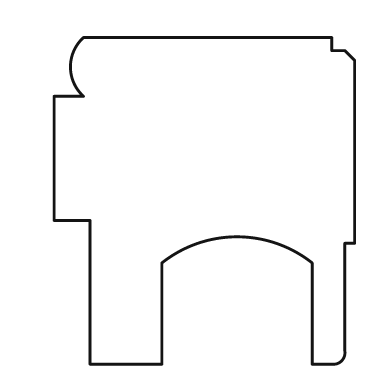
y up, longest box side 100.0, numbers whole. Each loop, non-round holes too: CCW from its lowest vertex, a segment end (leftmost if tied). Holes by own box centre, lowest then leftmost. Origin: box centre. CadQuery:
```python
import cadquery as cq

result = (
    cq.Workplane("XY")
    .moveTo(-35.0, -50.0)
    .lineTo(-13.0, -50.0)
    .lineTo(-13.0, -19.0)
    .threePointArc((10.0, -11.0), (33.0, -19.0))
    .lineTo(33.0, -50.0)
    .lineTo(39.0, -50.0)
    .threePointArc((42.0, -49.0), (43.0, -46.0))
    .lineTo(43.0, -13.0)
    .lineTo(46.0, -13.0)
    .lineTo(46.0, 43.0)
    .lineTo(43.0, 46.0)
    .lineTo(39.0, 46.0)
    .lineTo(39.0, 50.0)
    .lineTo(-37.0, 50.0)
    .threePointArc((-41.0, 41.0), (-37.0, 32.0))
    .lineTo(-46.0, 32.0)
    .lineTo(-46.0, -6.0)
    .lineTo(-35.0, -6.0)
    .close()
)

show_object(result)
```